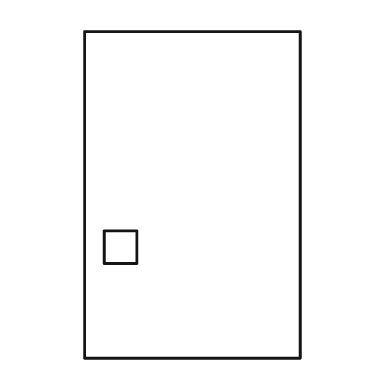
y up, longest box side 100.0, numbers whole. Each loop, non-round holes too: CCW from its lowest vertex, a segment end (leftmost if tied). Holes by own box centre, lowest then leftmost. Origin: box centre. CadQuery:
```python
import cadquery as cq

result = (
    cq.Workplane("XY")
    .moveTo(-33.0, -50.0)
    .lineTo(33.0, -50.0)
    .lineTo(33.0, 50.0)
    .lineTo(-33.0, 50.0)
    .close()
    .moveTo(-27.0, -21.0)
    .lineTo(-17.0, -21.0)
    .lineTo(-17.0, -11.0)
    .lineTo(-27.0, -11.0)
    .close()
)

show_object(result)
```